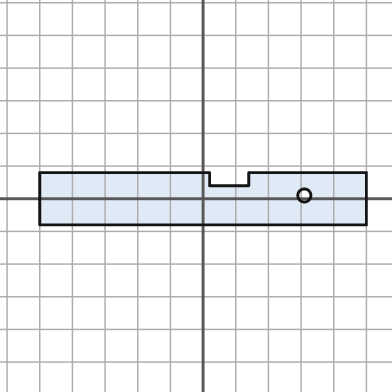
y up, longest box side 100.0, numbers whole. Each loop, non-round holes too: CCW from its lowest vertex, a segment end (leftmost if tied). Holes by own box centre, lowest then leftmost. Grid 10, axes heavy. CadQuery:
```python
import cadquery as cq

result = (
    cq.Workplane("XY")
    .moveTo(-50.0, -8.0)
    .lineTo(50.0, -8.0)
    .lineTo(50.0, 8.0)
    .lineTo(14.0, 8.0)
    .lineTo(14.0, 4.0)
    .lineTo(2.0, 4.0)
    .lineTo(2.0, 8.0)
    .lineTo(-50.0, 8.0)
    .close()
    .moveTo(31.0, 1.0)
    .circle(2.0)
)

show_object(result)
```